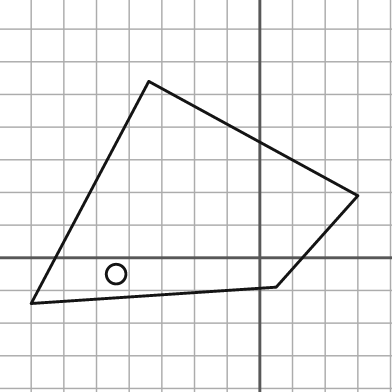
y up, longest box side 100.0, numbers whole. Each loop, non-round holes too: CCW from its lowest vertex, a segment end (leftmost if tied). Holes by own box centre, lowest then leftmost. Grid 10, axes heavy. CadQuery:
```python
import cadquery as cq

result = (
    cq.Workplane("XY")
    .moveTo(-70.0, -14.0)
    .lineTo(5.0, -9.0)
    .lineTo(30.0, 19.0)
    .lineTo(-34.0, 54.0)
    .close()
    .moveTo(-44.0, -5.0)
    .circle(3.0)
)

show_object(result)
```